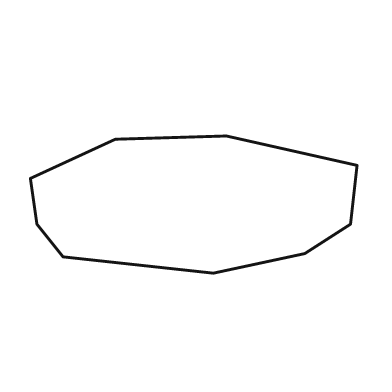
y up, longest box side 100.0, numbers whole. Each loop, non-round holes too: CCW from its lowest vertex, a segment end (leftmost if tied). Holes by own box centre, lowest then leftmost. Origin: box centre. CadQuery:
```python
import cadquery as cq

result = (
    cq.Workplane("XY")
    .moveTo(6.0, -21.0)
    .lineTo(34.0, -15.0)
    .lineTo(48.0, -6.0)
    .lineTo(50.0, 12.0)
    .lineTo(10.0, 21.0)
    .lineTo(-24.0, 20.0)
    .lineTo(-50.0, 8.0)
    .lineTo(-48.0, -6.0)
    .lineTo(-40.0, -16.0)
    .close()
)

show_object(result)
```